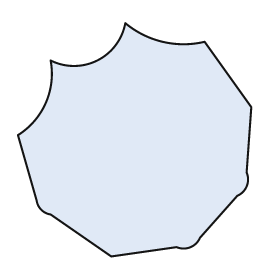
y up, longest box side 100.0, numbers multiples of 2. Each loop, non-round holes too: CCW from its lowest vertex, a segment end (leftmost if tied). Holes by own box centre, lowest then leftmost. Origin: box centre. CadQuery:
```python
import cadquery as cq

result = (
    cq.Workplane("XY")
    .moveTo(-10.0, -50.0)
    .lineTo(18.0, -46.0)
    .threePointArc((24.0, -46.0), (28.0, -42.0))
    .lineTo(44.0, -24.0)
    .threePointArc((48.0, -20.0), (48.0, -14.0))
    .lineTo(50.0, 14.0)
    .lineTo(30.0, 42.0)
    .threePointArc((12.0, 42.0), (-4.0, 50.0))
    .threePointArc((-16.0, 34.0), (-36.0, 34.0))
    .threePointArc((-38.0, 16.0), (-50.0, 2.0))
    .lineTo(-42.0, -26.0)
    .threePointArc((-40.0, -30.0), (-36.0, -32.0))
    .close()
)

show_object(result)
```